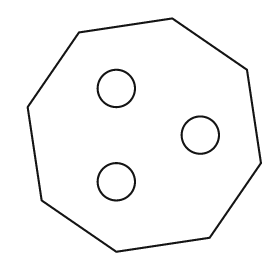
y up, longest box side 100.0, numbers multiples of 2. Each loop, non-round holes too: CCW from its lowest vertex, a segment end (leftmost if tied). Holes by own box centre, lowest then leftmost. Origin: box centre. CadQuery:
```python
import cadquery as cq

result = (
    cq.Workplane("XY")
    .moveTo(-12.0, -50.0)
    .lineTo(28.0, -44.0)
    .lineTo(50.0, -12.0)
    .lineTo(44.0, 28.0)
    .lineTo(12.0, 50.0)
    .lineTo(-28.0, 44.0)
    .lineTo(-50.0, 12.0)
    .lineTo(-44.0, -28.0)
    .close()
    .moveTo(-12.0, -20.0)
    .circle(8.0)
    .moveTo(24.0, 0.0)
    .circle(8.0)
    .moveTo(-12.0, 20.0)
    .circle(8.0)
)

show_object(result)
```